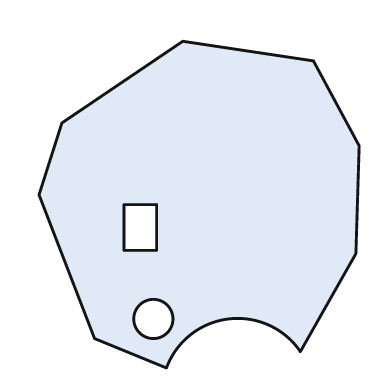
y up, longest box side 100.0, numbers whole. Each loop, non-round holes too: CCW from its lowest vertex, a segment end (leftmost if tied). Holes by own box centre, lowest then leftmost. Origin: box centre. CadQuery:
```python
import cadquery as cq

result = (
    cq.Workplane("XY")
    .moveTo(-10.0, -50.0)
    .threePointArc((9.0, -35.0), (31.0, -45.0))
    .lineTo(48.0, -15.0)
    .lineTo(49.0, 18.0)
    .lineTo(35.0, 44.0)
    .lineTo(-5.0, 50.0)
    .lineTo(-42.0, 25.0)
    .lineTo(-49.0, 3.0)
    .lineTo(-32.0, -41.0)
    .close()
    .moveTo(-14.0, -35.0)
    .circle(6.0)
    .moveTo(-23.0, -14.0)
    .lineTo(-13.0, -14.0)
    .lineTo(-13.0, 0.0)
    .lineTo(-23.0, 0.0)
    .close()
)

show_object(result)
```